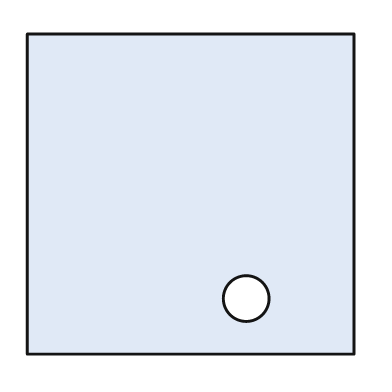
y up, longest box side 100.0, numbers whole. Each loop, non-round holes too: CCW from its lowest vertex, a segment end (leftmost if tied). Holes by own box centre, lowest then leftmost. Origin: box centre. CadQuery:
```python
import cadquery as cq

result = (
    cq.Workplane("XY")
    .moveTo(-50.0, -49.0)
    .lineTo(50.0, -49.0)
    .lineTo(50.0, 49.0)
    .lineTo(-50.0, 49.0)
    .close()
    .moveTo(17.0, -32.0)
    .circle(7.0)
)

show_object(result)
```